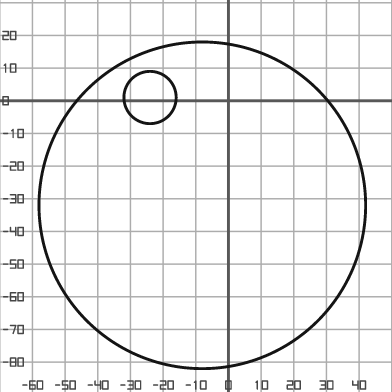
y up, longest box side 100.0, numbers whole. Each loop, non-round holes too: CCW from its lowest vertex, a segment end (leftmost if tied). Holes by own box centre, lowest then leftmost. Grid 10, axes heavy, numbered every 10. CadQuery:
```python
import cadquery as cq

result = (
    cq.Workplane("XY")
    .moveTo(-8.0, -32.0)
    .circle(50.0)
    .moveTo(-24.0, 1.0)
    .circle(8.0)
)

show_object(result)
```